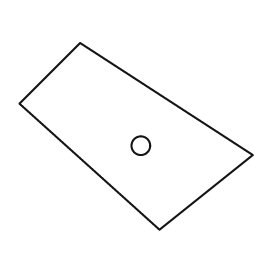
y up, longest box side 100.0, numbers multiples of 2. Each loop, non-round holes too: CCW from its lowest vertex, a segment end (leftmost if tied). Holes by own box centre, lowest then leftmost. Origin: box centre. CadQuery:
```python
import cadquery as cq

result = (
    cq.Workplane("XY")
    .moveTo(10.0, -40.0)
    .lineTo(50.0, -8.0)
    .lineTo(-24.0, 40.0)
    .lineTo(-50.0, 14.0)
    .close()
    .moveTo(2.0, -4.0)
    .circle(4.0)
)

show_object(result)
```